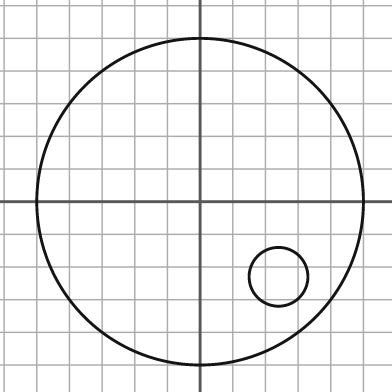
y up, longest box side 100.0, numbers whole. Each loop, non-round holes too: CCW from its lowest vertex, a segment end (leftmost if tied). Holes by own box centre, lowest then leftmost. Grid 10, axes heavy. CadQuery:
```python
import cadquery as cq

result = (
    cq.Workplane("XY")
    .moveTo(0.0, 0.0)
    .circle(50.0)
    .moveTo(24.0, -23.0)
    .circle(9.0)
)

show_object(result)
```